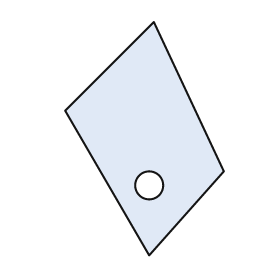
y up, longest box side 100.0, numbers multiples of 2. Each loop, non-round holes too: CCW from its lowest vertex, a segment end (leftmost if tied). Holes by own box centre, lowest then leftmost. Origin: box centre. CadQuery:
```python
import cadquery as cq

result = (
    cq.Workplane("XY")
    .moveTo(2.0, -50.0)
    .lineTo(34.0, -14.0)
    .lineTo(4.0, 50.0)
    .lineTo(-34.0, 12.0)
    .close()
    .moveTo(2.0, -20.0)
    .circle(6.0)
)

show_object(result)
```